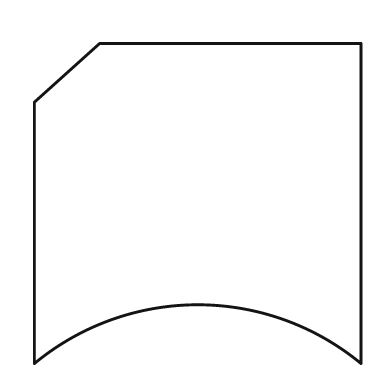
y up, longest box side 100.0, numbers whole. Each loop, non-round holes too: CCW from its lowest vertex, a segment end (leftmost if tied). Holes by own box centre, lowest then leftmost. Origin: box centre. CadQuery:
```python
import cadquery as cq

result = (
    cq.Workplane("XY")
    .moveTo(-50.0, -49.0)
    .threePointArc((0.0, -31.0), (50.0, -49.0))
    .lineTo(50.0, 49.0)
    .lineTo(-30.0, 49.0)
    .lineTo(-50.0, 31.0)
    .close()
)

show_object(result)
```